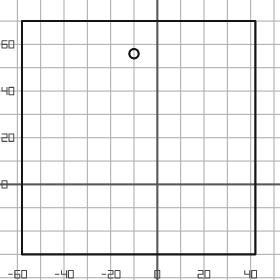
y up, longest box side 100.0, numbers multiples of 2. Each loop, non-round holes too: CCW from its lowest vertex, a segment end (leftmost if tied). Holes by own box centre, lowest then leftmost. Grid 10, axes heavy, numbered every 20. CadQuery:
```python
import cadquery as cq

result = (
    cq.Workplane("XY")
    .moveTo(-58.0, -30.0)
    .lineTo(42.0, -30.0)
    .lineTo(42.0, 70.0)
    .lineTo(-58.0, 70.0)
    .close()
    .moveTo(-10.0, 56.0)
    .circle(2.0)
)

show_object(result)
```